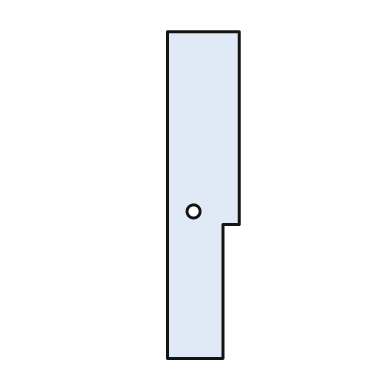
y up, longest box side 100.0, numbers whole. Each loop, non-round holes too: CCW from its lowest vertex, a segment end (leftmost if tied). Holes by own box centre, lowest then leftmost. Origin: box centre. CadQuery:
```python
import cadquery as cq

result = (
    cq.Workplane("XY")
    .moveTo(-11.0, -50.0)
    .lineTo(6.0, -50.0)
    .lineTo(6.0, -9.0)
    .lineTo(11.0, -9.0)
    .lineTo(11.0, 50.0)
    .lineTo(-11.0, 50.0)
    .close()
    .moveTo(-3.0, -5.0)
    .circle(2.0)
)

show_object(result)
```